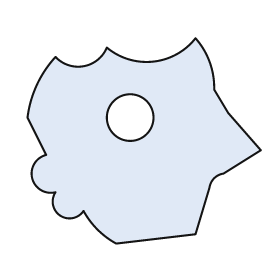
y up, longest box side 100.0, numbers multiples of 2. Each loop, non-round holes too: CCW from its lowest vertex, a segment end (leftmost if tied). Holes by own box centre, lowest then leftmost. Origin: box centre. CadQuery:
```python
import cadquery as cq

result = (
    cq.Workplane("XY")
    .moveTo(-12.0, -44.0)
    .lineTo(22.0, -40.0)
    .lineTo(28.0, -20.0)
    .threePointArc((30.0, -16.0), (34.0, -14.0))
    .lineTo(50.0, -4.0)
    .lineTo(36.0, 12.0)
    .lineTo(30.0, 22.0)
    .threePointArc((28.0, 34.0), (22.0, 44.0))
    .threePointArc((4.0, 34.0), (-16.0, 40.0))
    .threePointArc((-26.0, 32.0), (-38.0, 36.0))
    .threePointArc((-46.0, 24.0), (-50.0, 10.0))
    .lineTo(-42.0, -6.0)
    .threePointArc((-48.0, -16.0), (-38.0, -22.0))
    .threePointArc((-36.0, -32.0), (-26.0, -30.0))
    .threePointArc((-20.0, -38.0), (-12.0, -44.0))
    .close()
    .moveTo(-6.0, 10.0)
    .circle(10.0)
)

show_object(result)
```